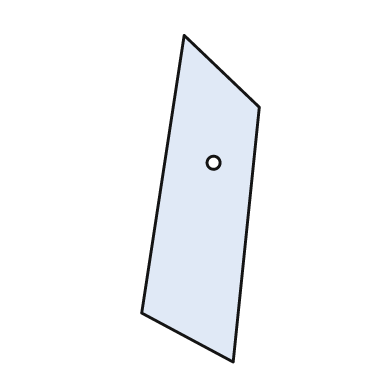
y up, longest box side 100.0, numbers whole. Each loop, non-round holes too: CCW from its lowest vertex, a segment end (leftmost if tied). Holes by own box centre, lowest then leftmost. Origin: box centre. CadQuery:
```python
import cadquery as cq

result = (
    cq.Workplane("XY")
    .moveTo(10.0, -50.0)
    .lineTo(18.0, 28.0)
    .lineTo(-5.0, 50.0)
    .lineTo(-18.0, -35.0)
    .close()
    .moveTo(4.0, 11.0)
    .circle(2.0)
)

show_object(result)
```